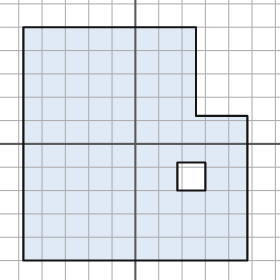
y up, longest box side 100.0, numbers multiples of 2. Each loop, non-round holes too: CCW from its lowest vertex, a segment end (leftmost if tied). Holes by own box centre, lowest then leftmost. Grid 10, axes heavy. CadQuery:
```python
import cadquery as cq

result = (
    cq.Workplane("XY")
    .moveTo(-48.0, -50.0)
    .lineTo(48.0, -50.0)
    .lineTo(48.0, 12.0)
    .lineTo(26.0, 12.0)
    .lineTo(26.0, 50.0)
    .lineTo(-48.0, 50.0)
    .close()
    .moveTo(18.0, -20.0)
    .lineTo(30.0, -20.0)
    .lineTo(30.0, -8.0)
    .lineTo(18.0, -8.0)
    .close()
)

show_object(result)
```